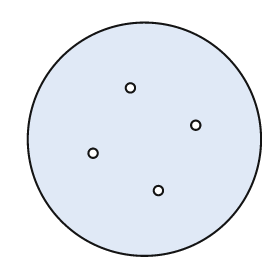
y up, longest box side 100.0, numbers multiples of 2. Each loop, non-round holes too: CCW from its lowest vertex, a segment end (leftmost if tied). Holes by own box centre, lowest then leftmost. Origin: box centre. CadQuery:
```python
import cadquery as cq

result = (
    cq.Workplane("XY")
    .moveTo(0.0, 0.0)
    .circle(50.0)
    .moveTo(6.0, -22.0)
    .circle(2.0)
    .moveTo(-22.0, -6.0)
    .circle(2.0)
    .moveTo(22.0, 6.0)
    .circle(2.0)
    .moveTo(-6.0, 22.0)
    .circle(2.0)
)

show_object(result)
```